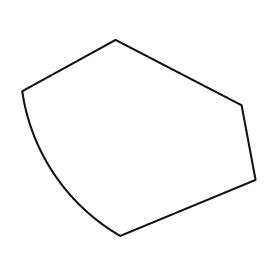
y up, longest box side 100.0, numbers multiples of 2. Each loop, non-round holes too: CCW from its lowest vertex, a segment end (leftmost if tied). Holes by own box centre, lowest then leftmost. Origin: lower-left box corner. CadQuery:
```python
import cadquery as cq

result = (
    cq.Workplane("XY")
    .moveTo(42.0, 0.0)
    .lineTo(100.0, 24.0)
    .lineTo(94.0, 56.0)
    .lineTo(40.0, 84.0)
    .lineTo(0.0, 62.0)
    .threePointArc((14.0, 26.0), (42.0, 0.0))
    .close()
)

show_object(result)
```